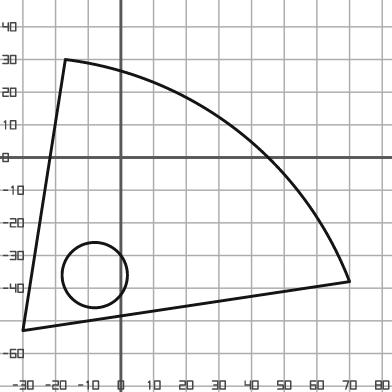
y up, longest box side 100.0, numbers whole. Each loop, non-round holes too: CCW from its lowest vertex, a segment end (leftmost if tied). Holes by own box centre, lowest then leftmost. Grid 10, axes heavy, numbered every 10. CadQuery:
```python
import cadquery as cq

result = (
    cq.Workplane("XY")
    .moveTo(-30.0, -53.0)
    .lineTo(70.0, -38.0)
    .threePointArc((36.0, 8.0), (-17.0, 30.0))
    .close()
    .moveTo(-8.0, -36.0)
    .circle(10.0)
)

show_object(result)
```